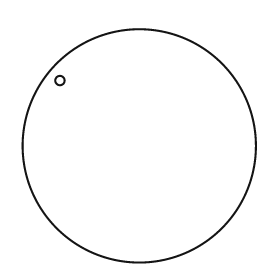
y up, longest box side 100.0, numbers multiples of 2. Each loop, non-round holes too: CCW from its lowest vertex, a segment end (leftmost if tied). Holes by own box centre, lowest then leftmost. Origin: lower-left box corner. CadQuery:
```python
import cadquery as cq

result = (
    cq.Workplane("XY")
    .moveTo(50.0, 50.0)
    .circle(50.0)
    .moveTo(16.0, 78.0)
    .circle(2.0)
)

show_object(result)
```